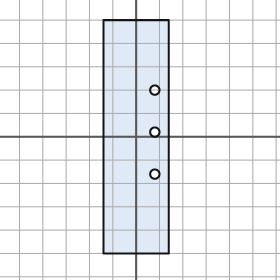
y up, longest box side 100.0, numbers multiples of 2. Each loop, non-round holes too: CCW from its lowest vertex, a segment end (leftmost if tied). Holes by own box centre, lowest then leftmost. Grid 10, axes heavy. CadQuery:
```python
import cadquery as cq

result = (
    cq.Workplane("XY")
    .moveTo(-14.0, -50.0)
    .lineTo(14.0, -50.0)
    .lineTo(14.0, 50.0)
    .lineTo(-14.0, 50.0)
    .close()
    .moveTo(8.0, -16.0)
    .circle(2.0)
    .moveTo(8.0, 2.0)
    .circle(2.0)
    .moveTo(8.0, 20.0)
    .circle(2.0)
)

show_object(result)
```